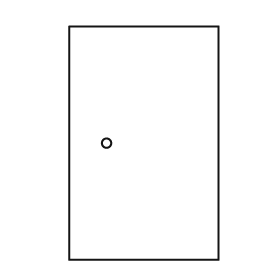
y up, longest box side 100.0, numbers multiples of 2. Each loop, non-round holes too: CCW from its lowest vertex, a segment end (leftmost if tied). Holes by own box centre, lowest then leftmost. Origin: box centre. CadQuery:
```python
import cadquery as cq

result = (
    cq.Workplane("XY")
    .moveTo(-32.0, -50.0)
    .lineTo(32.0, -50.0)
    .lineTo(32.0, 50.0)
    .lineTo(-32.0, 50.0)
    .close()
    .moveTo(-16.0, 0.0)
    .circle(2.0)
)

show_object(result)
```